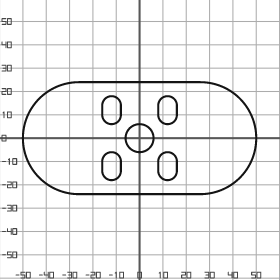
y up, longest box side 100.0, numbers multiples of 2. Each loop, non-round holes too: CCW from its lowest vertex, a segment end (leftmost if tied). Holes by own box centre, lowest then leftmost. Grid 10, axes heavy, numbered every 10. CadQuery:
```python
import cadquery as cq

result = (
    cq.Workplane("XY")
    .moveTo(-26.0, -24.0)
    .lineTo(26.0, -24.0)
    .threePointArc((50.0, 0.0), (26.0, 24.0))
    .lineTo(-26.0, 24.0)
    .threePointArc((-50.0, 0.0), (-26.0, -24.0))
    .close()
    .moveTo(-16.0, -14.0)
    .threePointArc((-12.0, -18.0), (-8.0, -14.0))
    .lineTo(-8.0, -10.0)
    .threePointArc((-12.0, -6.0), (-16.0, -10.0))
    .close()
    .moveTo(8.0, -14.0)
    .threePointArc((12.0, -18.0), (16.0, -14.0))
    .lineTo(16.0, -10.0)
    .threePointArc((12.0, -6.0), (8.0, -10.0))
    .close()
    .moveTo(0.0, 0.0)
    .circle(6.0)
    .moveTo(-16.0, 10.0)
    .threePointArc((-12.0, 6.0), (-8.0, 10.0))
    .lineTo(-8.0, 14.0)
    .threePointArc((-12.0, 18.0), (-16.0, 14.0))
    .close()
    .moveTo(8.0, 10.0)
    .threePointArc((12.0, 6.0), (16.0, 10.0))
    .lineTo(16.0, 14.0)
    .threePointArc((12.0, 18.0), (8.0, 14.0))
    .close()
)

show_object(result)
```